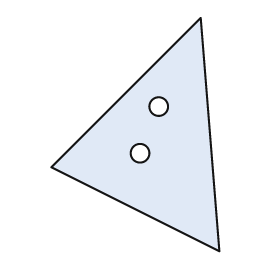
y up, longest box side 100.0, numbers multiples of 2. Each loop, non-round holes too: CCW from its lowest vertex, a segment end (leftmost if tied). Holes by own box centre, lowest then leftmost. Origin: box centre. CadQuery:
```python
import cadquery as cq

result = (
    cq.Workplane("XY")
    .moveTo(36.0, -50.0)
    .lineTo(28.0, 50.0)
    .lineTo(-36.0, -14.0)
    .close()
    .moveTo(2.0, -8.0)
    .circle(4.0)
    .moveTo(10.0, 12.0)
    .circle(4.0)
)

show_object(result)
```